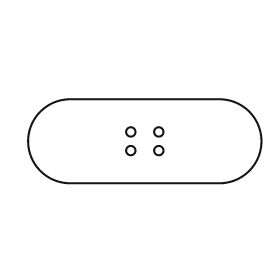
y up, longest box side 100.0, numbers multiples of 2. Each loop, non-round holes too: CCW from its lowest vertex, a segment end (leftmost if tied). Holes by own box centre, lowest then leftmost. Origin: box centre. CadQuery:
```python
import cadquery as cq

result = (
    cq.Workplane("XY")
    .moveTo(-32.0, -18.0)
    .lineTo(32.0, -18.0)
    .threePointArc((50.0, 0.0), (32.0, 18.0))
    .lineTo(-32.0, 18.0)
    .threePointArc((-50.0, 0.0), (-32.0, -18.0))
    .close()
    .moveTo(-6.0, -4.0)
    .circle(2.0)
    .moveTo(6.0, -4.0)
    .circle(2.0)
    .moveTo(-6.0, 4.0)
    .circle(2.0)
    .moveTo(6.0, 4.0)
    .circle(2.0)
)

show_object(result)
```